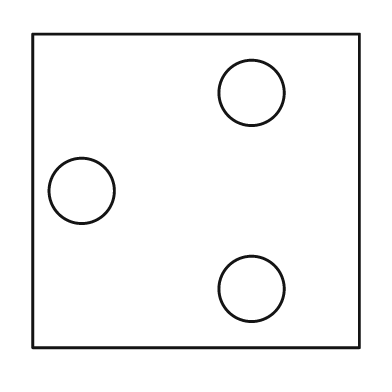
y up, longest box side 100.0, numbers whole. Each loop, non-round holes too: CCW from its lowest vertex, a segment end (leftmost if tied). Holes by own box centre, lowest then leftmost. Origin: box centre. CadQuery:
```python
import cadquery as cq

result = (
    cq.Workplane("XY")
    .moveTo(-50.0, -48.0)
    .lineTo(50.0, -48.0)
    .lineTo(50.0, 48.0)
    .lineTo(-50.0, 48.0)
    .close()
    .moveTo(17.0, -30.0)
    .circle(10.0)
    .moveTo(-35.0, 0.0)
    .circle(10.0)
    .moveTo(17.0, 30.0)
    .circle(10.0)
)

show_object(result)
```